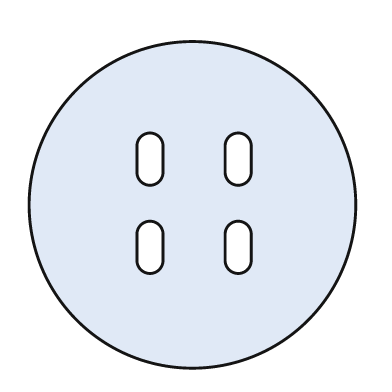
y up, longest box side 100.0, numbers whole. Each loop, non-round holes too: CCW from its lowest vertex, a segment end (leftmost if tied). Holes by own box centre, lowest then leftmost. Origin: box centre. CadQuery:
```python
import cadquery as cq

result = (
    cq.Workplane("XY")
    .moveTo(0.0, 0.0)
    .circle(50.0)
    .moveTo(-17.0, -17.0)
    .threePointArc((-13.0, -21.0), (-9.0, -17.0))
    .lineTo(-9.0, -9.0)
    .threePointArc((-13.0, -5.0), (-17.0, -9.0))
    .close()
    .moveTo(10.0, -17.0)
    .threePointArc((14.0, -21.0), (18.0, -17.0))
    .lineTo(18.0, -9.0)
    .threePointArc((14.0, -5.0), (10.0, -9.0))
    .close()
    .moveTo(-17.0, 10.0)
    .threePointArc((-13.0, 6.0), (-9.0, 10.0))
    .lineTo(-9.0, 18.0)
    .threePointArc((-13.0, 22.0), (-17.0, 18.0))
    .close()
    .moveTo(10.0, 10.0)
    .threePointArc((14.0, 6.0), (18.0, 10.0))
    .lineTo(18.0, 18.0)
    .threePointArc((14.0, 22.0), (10.0, 18.0))
    .close()
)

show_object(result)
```